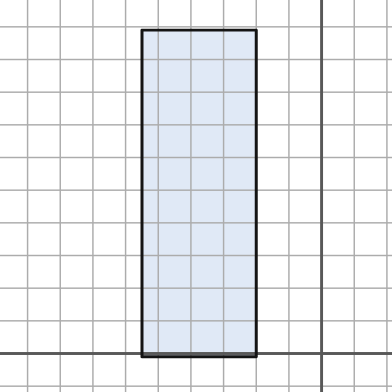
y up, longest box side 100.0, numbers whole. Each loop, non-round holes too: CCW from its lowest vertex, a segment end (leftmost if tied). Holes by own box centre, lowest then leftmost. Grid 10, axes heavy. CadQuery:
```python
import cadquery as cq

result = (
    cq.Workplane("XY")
    .moveTo(-55.0, -1.0)
    .lineTo(-20.0, -1.0)
    .lineTo(-20.0, 99.0)
    .lineTo(-55.0, 99.0)
    .close()
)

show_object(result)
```